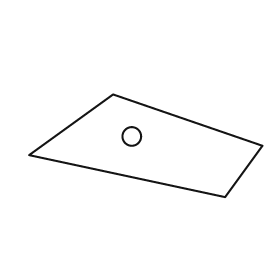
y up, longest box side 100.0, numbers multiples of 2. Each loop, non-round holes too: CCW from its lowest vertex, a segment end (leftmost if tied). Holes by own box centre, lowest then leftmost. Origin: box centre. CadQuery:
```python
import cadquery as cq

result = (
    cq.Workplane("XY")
    .moveTo(34.0, -22.0)
    .lineTo(50.0, 0.0)
    .lineTo(-14.0, 22.0)
    .lineTo(-50.0, -4.0)
    .close()
    .moveTo(-6.0, 4.0)
    .circle(4.0)
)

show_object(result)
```